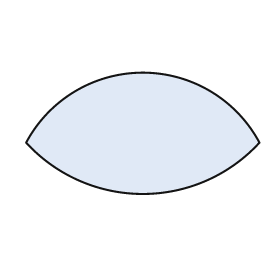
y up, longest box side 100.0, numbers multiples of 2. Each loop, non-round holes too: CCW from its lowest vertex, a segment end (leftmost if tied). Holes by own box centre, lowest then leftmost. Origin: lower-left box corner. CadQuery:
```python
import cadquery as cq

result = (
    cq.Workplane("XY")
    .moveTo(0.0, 22.0)
    .threePointArc((50.0, 0.0), (100.0, 22.0))
    .threePointArc((50.0, 52.0), (0.0, 22.0))
    .close()
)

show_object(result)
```